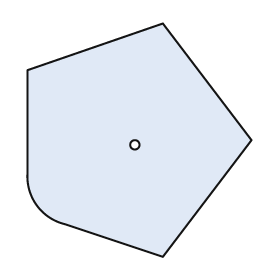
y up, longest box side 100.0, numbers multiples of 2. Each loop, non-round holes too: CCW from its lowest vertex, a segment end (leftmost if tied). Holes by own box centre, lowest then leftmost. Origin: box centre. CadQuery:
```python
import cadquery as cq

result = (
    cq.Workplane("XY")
    .moveTo(10.0, -50.0)
    .lineTo(48.0, 0.0)
    .lineTo(10.0, 50.0)
    .lineTo(-48.0, 30.0)
    .lineTo(-48.0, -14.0)
    .threePointArc((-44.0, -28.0), (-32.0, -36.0))
    .close()
    .moveTo(-2.0, -2.0)
    .circle(2.0)
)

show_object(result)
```